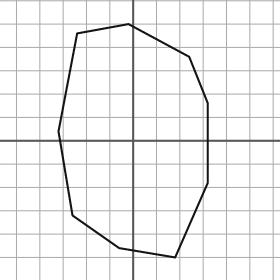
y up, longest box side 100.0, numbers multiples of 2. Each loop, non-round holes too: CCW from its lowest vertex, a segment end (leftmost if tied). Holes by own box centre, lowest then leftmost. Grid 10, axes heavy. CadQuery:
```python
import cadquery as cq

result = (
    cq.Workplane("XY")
    .moveTo(18.0, -50.0)
    .lineTo(32.0, -18.0)
    .lineTo(32.0, 16.0)
    .lineTo(24.0, 36.0)
    .lineTo(-2.0, 50.0)
    .lineTo(-24.0, 46.0)
    .lineTo(-32.0, 4.0)
    .lineTo(-26.0, -32.0)
    .lineTo(-6.0, -46.0)
    .close()
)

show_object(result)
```